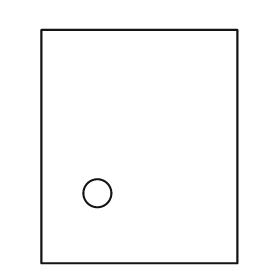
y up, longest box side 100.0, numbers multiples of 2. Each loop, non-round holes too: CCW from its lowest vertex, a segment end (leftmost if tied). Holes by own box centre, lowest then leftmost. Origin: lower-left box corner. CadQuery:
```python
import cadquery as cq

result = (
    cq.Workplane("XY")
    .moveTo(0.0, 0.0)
    .lineTo(84.0, 0.0)
    .lineTo(84.0, 100.0)
    .lineTo(0.0, 100.0)
    .close()
    .moveTo(24.0, 30.0)
    .circle(6.0)
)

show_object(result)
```